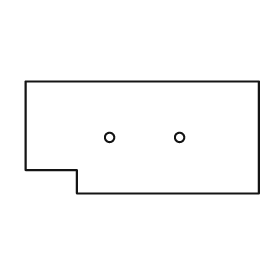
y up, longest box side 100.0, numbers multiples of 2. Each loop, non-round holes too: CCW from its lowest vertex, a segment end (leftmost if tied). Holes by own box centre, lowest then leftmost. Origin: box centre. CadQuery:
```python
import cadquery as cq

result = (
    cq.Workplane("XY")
    .moveTo(-28.0, -24.0)
    .lineTo(50.0, -24.0)
    .lineTo(50.0, 24.0)
    .lineTo(-50.0, 24.0)
    .lineTo(-50.0, -14.0)
    .lineTo(-28.0, -14.0)
    .close()
    .moveTo(-14.0, 0.0)
    .circle(2.0)
    .moveTo(16.0, 0.0)
    .circle(2.0)
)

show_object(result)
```